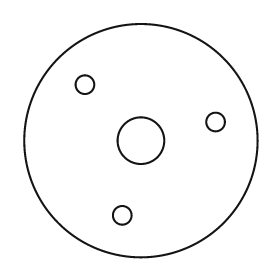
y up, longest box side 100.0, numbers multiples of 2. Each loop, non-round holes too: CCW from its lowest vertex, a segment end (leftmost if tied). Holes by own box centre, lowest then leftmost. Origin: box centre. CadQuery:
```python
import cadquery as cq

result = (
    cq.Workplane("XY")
    .moveTo(0.0, 0.0)
    .circle(50.0)
    .moveTo(-8.0, -32.0)
    .circle(4.0)
    .moveTo(0.0, 0.0)
    .circle(10.0)
    .moveTo(32.0, 8.0)
    .circle(4.0)
    .moveTo(-24.0, 24.0)
    .circle(4.0)
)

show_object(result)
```